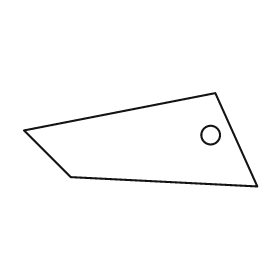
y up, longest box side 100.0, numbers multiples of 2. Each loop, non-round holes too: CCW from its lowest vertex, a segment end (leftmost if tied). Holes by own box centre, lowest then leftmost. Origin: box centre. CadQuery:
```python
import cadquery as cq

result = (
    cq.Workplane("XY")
    .moveTo(50.0, -20.0)
    .lineTo(32.0, 20.0)
    .lineTo(-50.0, 4.0)
    .lineTo(-30.0, -16.0)
    .close()
    .moveTo(30.0, 2.0)
    .circle(4.0)
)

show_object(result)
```